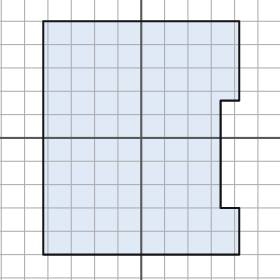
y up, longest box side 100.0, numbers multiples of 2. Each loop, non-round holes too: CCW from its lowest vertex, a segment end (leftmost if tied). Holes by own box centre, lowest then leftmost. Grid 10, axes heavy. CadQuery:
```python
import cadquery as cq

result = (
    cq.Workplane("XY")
    .moveTo(-42.0, -50.0)
    .lineTo(42.0, -50.0)
    .lineTo(42.0, -30.0)
    .lineTo(34.0, -30.0)
    .lineTo(34.0, 16.0)
    .lineTo(42.0, 16.0)
    .lineTo(42.0, 50.0)
    .lineTo(-42.0, 50.0)
    .close()
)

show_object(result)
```